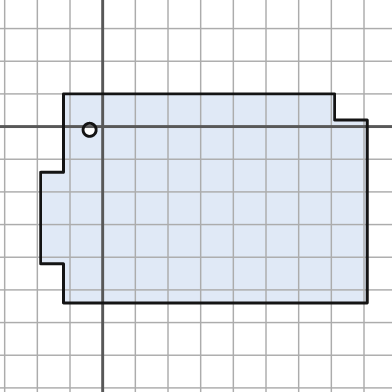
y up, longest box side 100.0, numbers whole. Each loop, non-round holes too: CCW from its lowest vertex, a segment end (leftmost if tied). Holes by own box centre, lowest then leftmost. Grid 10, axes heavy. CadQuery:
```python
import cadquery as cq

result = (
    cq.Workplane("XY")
    .moveTo(-12.0, -54.0)
    .lineTo(81.0, -54.0)
    .lineTo(81.0, 2.0)
    .lineTo(71.0, 2.0)
    .lineTo(71.0, 10.0)
    .lineTo(-12.0, 10.0)
    .lineTo(-12.0, -14.0)
    .lineTo(-19.0, -14.0)
    .lineTo(-19.0, -42.0)
    .lineTo(-12.0, -42.0)
    .close()
    .moveTo(-4.0, -1.0)
    .circle(2.0)
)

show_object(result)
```